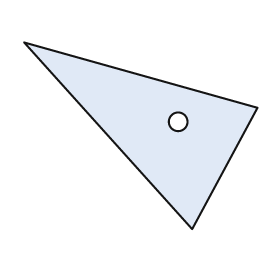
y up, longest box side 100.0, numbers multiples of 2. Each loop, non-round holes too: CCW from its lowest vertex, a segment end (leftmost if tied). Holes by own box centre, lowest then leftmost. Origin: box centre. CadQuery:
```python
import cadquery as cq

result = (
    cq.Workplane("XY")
    .moveTo(22.0, -40.0)
    .lineTo(50.0, 12.0)
    .lineTo(-50.0, 40.0)
    .close()
    .moveTo(16.0, 6.0)
    .circle(4.0)
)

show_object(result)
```